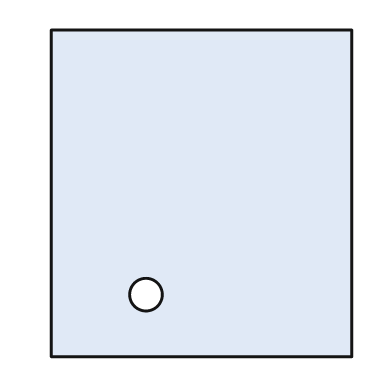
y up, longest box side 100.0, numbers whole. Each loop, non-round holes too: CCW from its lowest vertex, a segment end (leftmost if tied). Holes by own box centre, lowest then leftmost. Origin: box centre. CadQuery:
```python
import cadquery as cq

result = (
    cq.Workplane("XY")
    .moveTo(-46.0, -50.0)
    .lineTo(46.0, -50.0)
    .lineTo(46.0, 50.0)
    .lineTo(-46.0, 50.0)
    .close()
    .moveTo(-17.0, -31.0)
    .circle(5.0)
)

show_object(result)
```